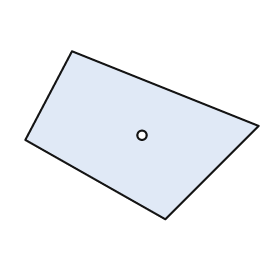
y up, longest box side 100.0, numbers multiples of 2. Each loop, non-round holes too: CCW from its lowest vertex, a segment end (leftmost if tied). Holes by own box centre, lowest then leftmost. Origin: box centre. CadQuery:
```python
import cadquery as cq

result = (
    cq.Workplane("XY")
    .moveTo(10.0, -36.0)
    .lineTo(50.0, 4.0)
    .lineTo(-30.0, 36.0)
    .lineTo(-50.0, -2.0)
    .close()
    .moveTo(0.0, 0.0)
    .circle(2.0)
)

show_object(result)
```